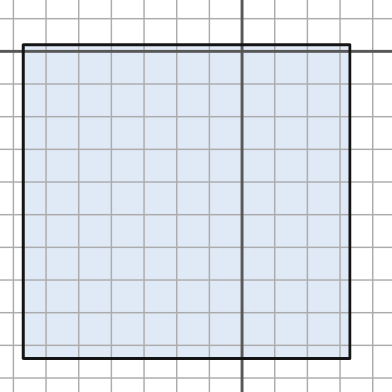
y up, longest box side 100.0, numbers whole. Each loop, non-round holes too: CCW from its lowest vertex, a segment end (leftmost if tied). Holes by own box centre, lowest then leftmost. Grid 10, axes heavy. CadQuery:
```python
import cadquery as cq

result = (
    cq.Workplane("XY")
    .moveTo(-67.0, -94.0)
    .lineTo(33.0, -94.0)
    .lineTo(33.0, 2.0)
    .lineTo(-67.0, 2.0)
    .close()
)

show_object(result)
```